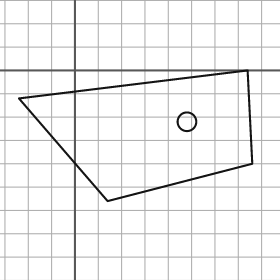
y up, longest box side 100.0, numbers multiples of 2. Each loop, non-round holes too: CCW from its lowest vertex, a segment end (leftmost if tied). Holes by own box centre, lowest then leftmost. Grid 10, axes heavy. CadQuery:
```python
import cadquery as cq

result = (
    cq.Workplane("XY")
    .moveTo(14.0, -56.0)
    .lineTo(76.0, -40.0)
    .lineTo(74.0, 0.0)
    .lineTo(-24.0, -12.0)
    .close()
    .moveTo(48.0, -22.0)
    .circle(4.0)
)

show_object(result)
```